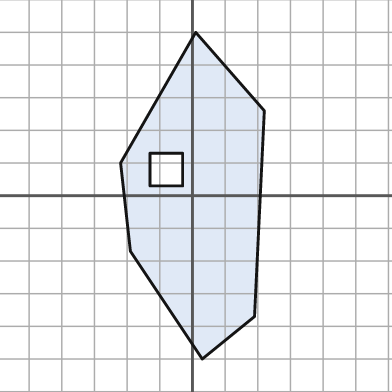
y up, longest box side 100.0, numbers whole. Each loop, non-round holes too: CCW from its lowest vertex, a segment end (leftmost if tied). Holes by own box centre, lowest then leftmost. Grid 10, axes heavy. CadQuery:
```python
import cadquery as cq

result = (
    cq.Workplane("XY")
    .moveTo(3.0, -50.0)
    .lineTo(19.0, -37.0)
    .lineTo(22.0, 26.0)
    .lineTo(1.0, 50.0)
    .lineTo(-22.0, 10.0)
    .lineTo(-19.0, -17.0)
    .close()
    .moveTo(-13.0, 3.0)
    .lineTo(-3.0, 3.0)
    .lineTo(-3.0, 13.0)
    .lineTo(-13.0, 13.0)
    .close()
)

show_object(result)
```